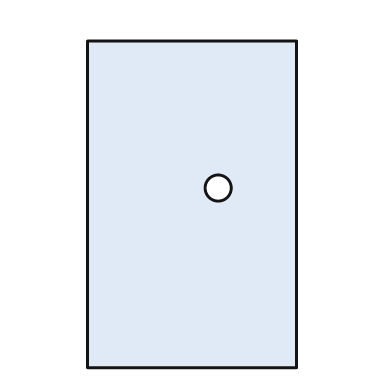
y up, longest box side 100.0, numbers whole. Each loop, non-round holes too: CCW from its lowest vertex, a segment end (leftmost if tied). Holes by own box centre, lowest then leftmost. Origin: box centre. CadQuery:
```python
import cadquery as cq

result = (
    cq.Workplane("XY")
    .moveTo(-32.0, -50.0)
    .lineTo(32.0, -50.0)
    .lineTo(32.0, 50.0)
    .lineTo(-32.0, 50.0)
    .close()
    .moveTo(8.0, 5.0)
    .circle(4.0)
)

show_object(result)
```